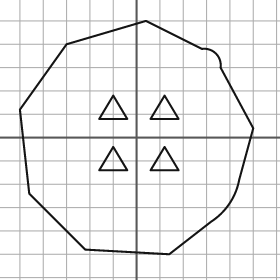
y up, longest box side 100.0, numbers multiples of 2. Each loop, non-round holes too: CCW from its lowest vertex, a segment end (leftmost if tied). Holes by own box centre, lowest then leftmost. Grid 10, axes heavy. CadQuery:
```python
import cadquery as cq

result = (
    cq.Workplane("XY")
    .moveTo(14.0, -50.0)
    .lineTo(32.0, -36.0)
    .threePointArc((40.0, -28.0), (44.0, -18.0))
    .lineTo(50.0, 4.0)
    .lineTo(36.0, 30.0)
    .threePointArc((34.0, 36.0), (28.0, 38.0))
    .lineTo(4.0, 50.0)
    .lineTo(-30.0, 40.0)
    .lineTo(-50.0, 12.0)
    .lineTo(-46.0, -24.0)
    .lineTo(-22.0, -48.0)
    .close()
    .moveTo(-16.0, -14.0)
    .lineTo(-4.0, -14.0)
    .lineTo(-10.0, -4.0)
    .close()
    .moveTo(6.0, -14.0)
    .lineTo(18.0, -14.0)
    .lineTo(12.0, -4.0)
    .close()
    .moveTo(-16.0, 8.0)
    .lineTo(-4.0, 8.0)
    .lineTo(-10.0, 18.0)
    .close()
    .moveTo(6.0, 8.0)
    .lineTo(18.0, 8.0)
    .lineTo(12.0, 18.0)
    .close()
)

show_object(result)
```